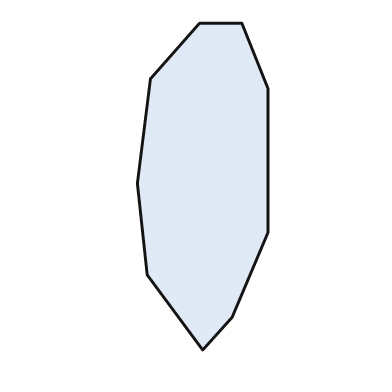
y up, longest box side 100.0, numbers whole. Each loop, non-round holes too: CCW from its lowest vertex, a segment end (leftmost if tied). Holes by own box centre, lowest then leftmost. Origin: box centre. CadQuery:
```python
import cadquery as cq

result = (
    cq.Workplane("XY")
    .moveTo(0.0, -50.0)
    .lineTo(9.0, -40.0)
    .lineTo(20.0, -14.0)
    .lineTo(20.0, 30.0)
    .lineTo(12.0, 50.0)
    .lineTo(-1.0, 50.0)
    .lineTo(-16.0, 33.0)
    .lineTo(-20.0, 1.0)
    .lineTo(-17.0, -27.0)
    .close()
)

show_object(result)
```